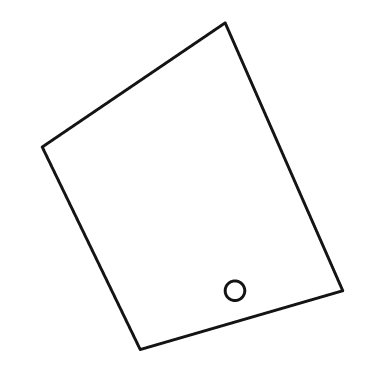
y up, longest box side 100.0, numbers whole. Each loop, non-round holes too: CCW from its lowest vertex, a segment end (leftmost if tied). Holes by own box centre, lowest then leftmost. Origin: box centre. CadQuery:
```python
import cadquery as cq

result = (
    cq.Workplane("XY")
    .moveTo(-16.0, -50.0)
    .lineTo(46.0, -32.0)
    .lineTo(10.0, 50.0)
    .lineTo(-46.0, 12.0)
    .close()
    .moveTo(13.0, -32.0)
    .circle(3.0)
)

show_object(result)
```